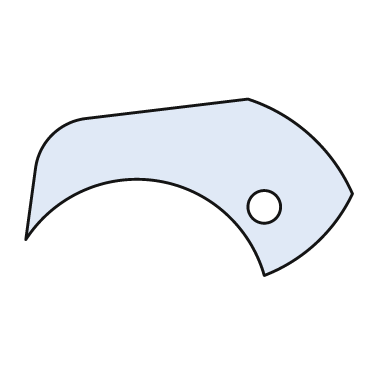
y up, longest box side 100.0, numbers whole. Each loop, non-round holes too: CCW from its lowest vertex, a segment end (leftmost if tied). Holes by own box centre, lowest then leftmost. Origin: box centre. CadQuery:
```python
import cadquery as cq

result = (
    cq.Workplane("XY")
    .moveTo(23.0, -27.0)
    .threePointArc((39.0, -17.0), (50.0, -2.0))
    .threePointArc((37.0, 16.0), (18.0, 27.0))
    .lineTo(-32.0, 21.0)
    .threePointArc((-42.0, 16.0), (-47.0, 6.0))
    .lineTo(-50.0, -16.0)
    .threePointArc((-10.0, 2.0), (23.0, -27.0))
    .close()
    .moveTo(23.0, -6.0)
    .circle(5.0)
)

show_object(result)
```